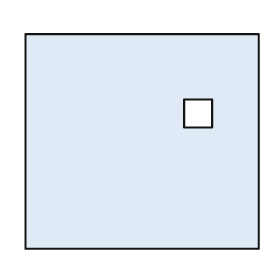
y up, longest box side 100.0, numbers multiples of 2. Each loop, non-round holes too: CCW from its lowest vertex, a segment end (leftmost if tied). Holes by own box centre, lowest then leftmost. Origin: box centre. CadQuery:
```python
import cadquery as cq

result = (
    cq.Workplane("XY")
    .moveTo(-50.0, -46.0)
    .lineTo(50.0, -46.0)
    .lineTo(50.0, 46.0)
    .lineTo(-50.0, 46.0)
    .close()
    .moveTo(18.0, 6.0)
    .lineTo(30.0, 6.0)
    .lineTo(30.0, 18.0)
    .lineTo(18.0, 18.0)
    .close()
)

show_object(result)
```